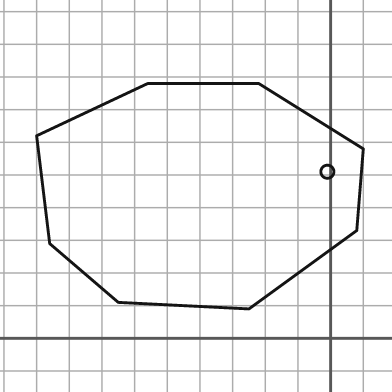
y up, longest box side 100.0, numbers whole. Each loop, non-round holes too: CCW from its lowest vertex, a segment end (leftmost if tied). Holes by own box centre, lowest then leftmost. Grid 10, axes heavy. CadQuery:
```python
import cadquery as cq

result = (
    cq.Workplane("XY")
    .moveTo(-25.0, 9.0)
    .lineTo(8.0, 33.0)
    .lineTo(10.0, 58.0)
    .lineTo(-22.0, 78.0)
    .lineTo(-56.0, 78.0)
    .lineTo(-90.0, 62.0)
    .lineTo(-86.0, 29.0)
    .lineTo(-65.0, 11.0)
    .close()
    .moveTo(-1.0, 51.0)
    .circle(2.0)
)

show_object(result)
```